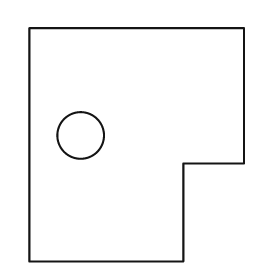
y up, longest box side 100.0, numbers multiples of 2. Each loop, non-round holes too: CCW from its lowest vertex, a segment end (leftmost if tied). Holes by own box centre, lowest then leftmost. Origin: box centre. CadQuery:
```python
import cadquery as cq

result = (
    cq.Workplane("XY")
    .moveTo(-46.0, -50.0)
    .lineTo(20.0, -50.0)
    .lineTo(20.0, -8.0)
    .lineTo(46.0, -8.0)
    .lineTo(46.0, 50.0)
    .lineTo(-46.0, 50.0)
    .close()
    .moveTo(-24.0, 4.0)
    .circle(10.0)
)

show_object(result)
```